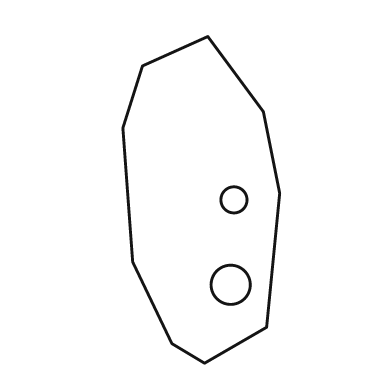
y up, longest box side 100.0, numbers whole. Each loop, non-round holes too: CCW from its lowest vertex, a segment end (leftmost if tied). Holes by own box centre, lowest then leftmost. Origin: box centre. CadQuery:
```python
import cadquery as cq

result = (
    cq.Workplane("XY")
    .moveTo(1.0, -50.0)
    .lineTo(20.0, -39.0)
    .lineTo(24.0, 2.0)
    .lineTo(19.0, 27.0)
    .lineTo(2.0, 50.0)
    .lineTo(-18.0, 41.0)
    .lineTo(-24.0, 22.0)
    .lineTo(-21.0, -19.0)
    .lineTo(-9.0, -44.0)
    .close()
    .moveTo(9.0, -26.0)
    .circle(6.0)
    .moveTo(10.0, 0.0)
    .circle(4.0)
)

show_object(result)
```